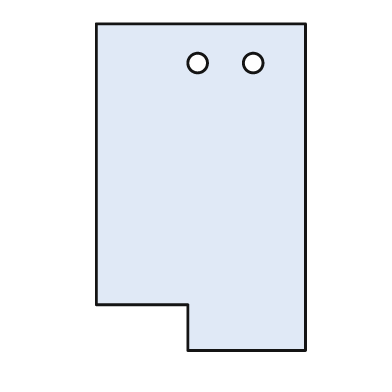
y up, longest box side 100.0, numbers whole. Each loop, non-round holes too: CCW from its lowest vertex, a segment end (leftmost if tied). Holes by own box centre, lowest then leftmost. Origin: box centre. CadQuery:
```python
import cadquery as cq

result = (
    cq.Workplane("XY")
    .moveTo(-4.0, -50.0)
    .lineTo(32.0, -50.0)
    .lineTo(32.0, 50.0)
    .lineTo(-32.0, 50.0)
    .lineTo(-32.0, -36.0)
    .lineTo(-4.0, -36.0)
    .close()
    .moveTo(-1.0, 38.0)
    .circle(3.0)
    .moveTo(16.0, 38.0)
    .circle(3.0)
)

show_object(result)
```